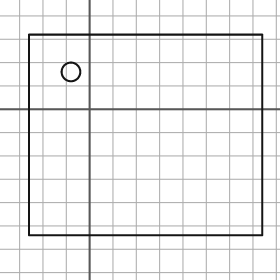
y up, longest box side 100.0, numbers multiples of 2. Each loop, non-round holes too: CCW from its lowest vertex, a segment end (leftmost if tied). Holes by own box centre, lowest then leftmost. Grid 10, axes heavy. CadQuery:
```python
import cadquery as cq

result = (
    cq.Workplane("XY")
    .moveTo(-26.0, -54.0)
    .lineTo(74.0, -54.0)
    .lineTo(74.0, 32.0)
    .lineTo(-26.0, 32.0)
    .close()
    .moveTo(-8.0, 16.0)
    .circle(4.0)
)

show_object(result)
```